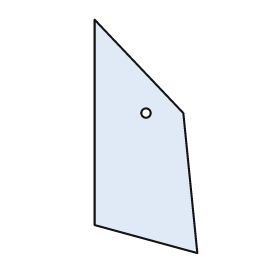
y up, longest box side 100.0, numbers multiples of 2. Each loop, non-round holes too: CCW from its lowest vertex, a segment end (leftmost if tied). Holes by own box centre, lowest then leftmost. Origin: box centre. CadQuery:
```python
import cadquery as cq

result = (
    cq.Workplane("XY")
    .moveTo(22.0, -50.0)
    .lineTo(16.0, 10.0)
    .lineTo(-22.0, 50.0)
    .lineTo(-22.0, -38.0)
    .close()
    .moveTo(0.0, 10.0)
    .circle(2.0)
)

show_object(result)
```